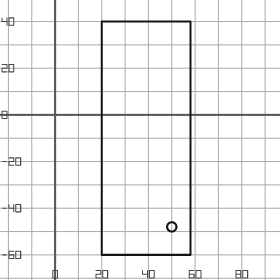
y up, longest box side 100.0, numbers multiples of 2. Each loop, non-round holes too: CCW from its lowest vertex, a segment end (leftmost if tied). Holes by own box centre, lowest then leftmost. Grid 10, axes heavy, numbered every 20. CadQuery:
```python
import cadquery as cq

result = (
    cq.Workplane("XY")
    .moveTo(20.0, -60.0)
    .lineTo(58.0, -60.0)
    .lineTo(58.0, 40.0)
    .lineTo(20.0, 40.0)
    .close()
    .moveTo(50.0, -48.0)
    .circle(2.0)
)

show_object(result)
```